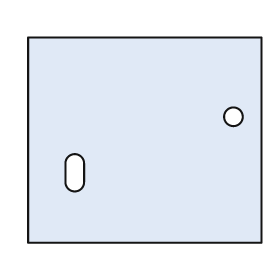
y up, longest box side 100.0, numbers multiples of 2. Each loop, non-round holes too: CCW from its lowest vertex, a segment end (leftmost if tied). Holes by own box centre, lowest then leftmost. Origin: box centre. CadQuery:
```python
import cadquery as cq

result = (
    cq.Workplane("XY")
    .moveTo(-50.0, -44.0)
    .lineTo(50.0, -44.0)
    .lineTo(50.0, 44.0)
    .lineTo(-50.0, 44.0)
    .close()
    .moveTo(-34.0, -18.0)
    .threePointArc((-30.0, -22.0), (-26.0, -18.0))
    .lineTo(-26.0, -10.0)
    .threePointArc((-30.0, -6.0), (-34.0, -10.0))
    .close()
    .moveTo(38.0, 10.0)
    .circle(4.0)
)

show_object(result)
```